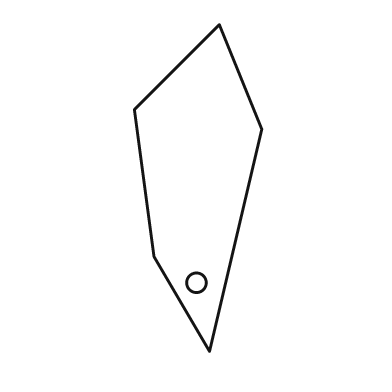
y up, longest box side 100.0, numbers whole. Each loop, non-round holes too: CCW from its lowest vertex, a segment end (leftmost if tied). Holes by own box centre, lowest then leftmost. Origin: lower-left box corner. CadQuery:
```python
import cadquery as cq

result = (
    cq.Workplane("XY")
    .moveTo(23.0, 0.0)
    .lineTo(39.0, 68.0)
    .lineTo(26.0, 100.0)
    .lineTo(0.0, 74.0)
    .lineTo(6.0, 29.0)
    .close()
    .moveTo(19.0, 21.0)
    .circle(3.0)
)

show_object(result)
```